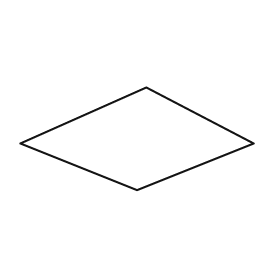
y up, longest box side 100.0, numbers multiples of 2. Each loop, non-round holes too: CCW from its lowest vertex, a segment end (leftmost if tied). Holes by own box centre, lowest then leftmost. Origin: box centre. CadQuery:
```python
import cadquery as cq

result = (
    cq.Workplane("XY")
    .moveTo(0.0, -22.0)
    .lineTo(50.0, -2.0)
    .lineTo(4.0, 22.0)
    .lineTo(-50.0, -2.0)
    .close()
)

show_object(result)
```